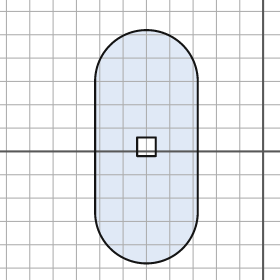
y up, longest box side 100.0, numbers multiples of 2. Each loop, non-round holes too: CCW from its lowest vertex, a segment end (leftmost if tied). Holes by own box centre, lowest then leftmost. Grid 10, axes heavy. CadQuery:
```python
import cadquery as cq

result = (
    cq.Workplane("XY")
    .moveTo(-72.0, -26.0)
    .threePointArc((-50.0, -48.0), (-28.0, -26.0))
    .lineTo(-28.0, 30.0)
    .threePointArc((-50.0, 52.0), (-72.0, 30.0))
    .close()
    .moveTo(-54.0, -2.0)
    .lineTo(-46.0, -2.0)
    .lineTo(-46.0, 6.0)
    .lineTo(-54.0, 6.0)
    .close()
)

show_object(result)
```